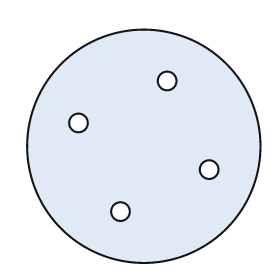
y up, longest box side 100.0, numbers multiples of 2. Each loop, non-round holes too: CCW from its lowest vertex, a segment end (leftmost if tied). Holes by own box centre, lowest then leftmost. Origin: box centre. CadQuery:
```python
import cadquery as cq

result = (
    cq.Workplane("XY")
    .moveTo(0.0, 0.0)
    .circle(50.0)
    .moveTo(-10.0, -28.0)
    .circle(4.0)
    .moveTo(28.0, -10.0)
    .circle(4.0)
    .moveTo(-28.0, 10.0)
    .circle(4.0)
    .moveTo(10.0, 28.0)
    .circle(4.0)
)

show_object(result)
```